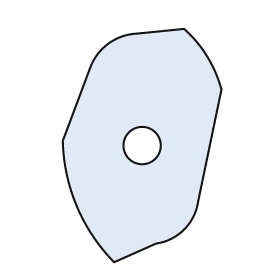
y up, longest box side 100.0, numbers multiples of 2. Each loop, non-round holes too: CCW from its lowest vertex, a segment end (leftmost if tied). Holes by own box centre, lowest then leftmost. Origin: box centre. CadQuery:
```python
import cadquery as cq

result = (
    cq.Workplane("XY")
    .moveTo(-12.0, -50.0)
    .lineTo(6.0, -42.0)
    .threePointArc((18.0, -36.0), (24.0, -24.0))
    .lineTo(34.0, 24.0)
    .threePointArc((28.0, 38.0), (18.0, 50.0))
    .lineTo(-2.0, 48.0)
    .threePointArc((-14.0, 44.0), (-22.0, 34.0))
    .lineTo(-34.0, 2.0)
    .threePointArc((-28.0, -26.0), (-12.0, -50.0))
    .close()
    .moveTo(0.0, 0.0)
    .circle(8.0)
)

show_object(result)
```